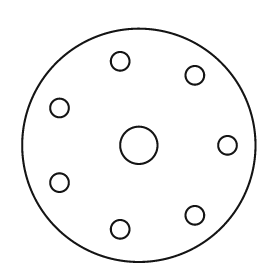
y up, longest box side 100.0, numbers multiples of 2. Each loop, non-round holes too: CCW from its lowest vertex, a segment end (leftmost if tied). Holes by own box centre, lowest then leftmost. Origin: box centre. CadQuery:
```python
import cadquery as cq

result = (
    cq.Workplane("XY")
    .moveTo(0.0, 0.0)
    .circle(50.0)
    .moveTo(-8.0, -36.0)
    .circle(4.0)
    .moveTo(24.0, -30.0)
    .circle(4.0)
    .moveTo(-34.0, -16.0)
    .circle(4.0)
    .moveTo(0.0, 0.0)
    .circle(8.0)
    .moveTo(38.0, 0.0)
    .circle(4.0)
    .moveTo(-34.0, 16.0)
    .circle(4.0)
    .moveTo(24.0, 30.0)
    .circle(4.0)
    .moveTo(-8.0, 36.0)
    .circle(4.0)
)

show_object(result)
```